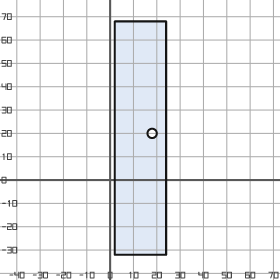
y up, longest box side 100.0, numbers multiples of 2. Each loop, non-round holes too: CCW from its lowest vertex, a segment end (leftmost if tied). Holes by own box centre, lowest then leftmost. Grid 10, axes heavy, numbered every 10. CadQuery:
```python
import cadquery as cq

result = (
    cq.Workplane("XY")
    .moveTo(2.0, -32.0)
    .lineTo(24.0, -32.0)
    .lineTo(24.0, 68.0)
    .lineTo(2.0, 68.0)
    .close()
    .moveTo(18.0, 20.0)
    .circle(2.0)
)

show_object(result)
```